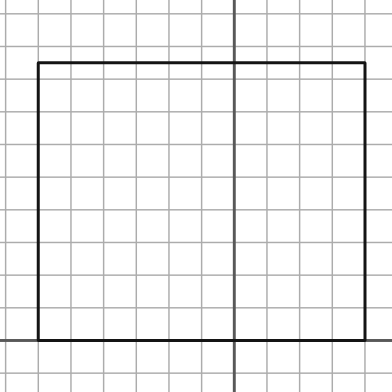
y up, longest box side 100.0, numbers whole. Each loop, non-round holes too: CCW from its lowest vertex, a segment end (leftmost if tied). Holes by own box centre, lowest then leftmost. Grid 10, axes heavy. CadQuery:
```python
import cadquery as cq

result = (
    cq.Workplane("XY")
    .moveTo(-60.0, 0.0)
    .lineTo(40.0, 0.0)
    .lineTo(40.0, 85.0)
    .lineTo(-60.0, 85.0)
    .close()
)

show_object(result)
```